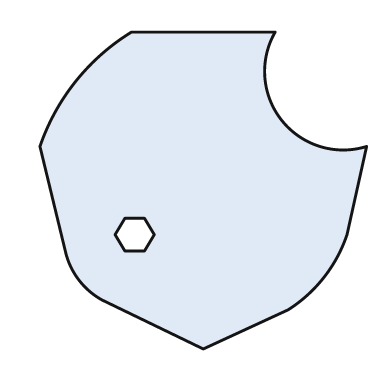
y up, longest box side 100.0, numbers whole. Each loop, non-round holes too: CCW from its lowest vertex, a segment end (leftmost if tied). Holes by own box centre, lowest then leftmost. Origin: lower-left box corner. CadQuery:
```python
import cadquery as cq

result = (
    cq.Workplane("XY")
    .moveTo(50.0, 0.0)
    .lineTo(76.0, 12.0)
    .threePointArc((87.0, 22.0), (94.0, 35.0))
    .lineTo(100.0, 62.0)
    .threePointArc((74.0, 70.0), (72.0, 97.0))
    .lineTo(28.0, 97.0)
    .threePointArc((11.0, 82.0), (0.0, 62.0))
    .lineTo(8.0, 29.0)
    .threePointArc((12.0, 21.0), (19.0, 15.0))
    .close()
    .moveTo(26.0, 30.0)
    .lineTo(32.0, 30.0)
    .lineTo(35.0, 35.0)
    .lineTo(32.0, 40.0)
    .lineTo(26.0, 40.0)
    .lineTo(23.0, 35.0)
    .close()
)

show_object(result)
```